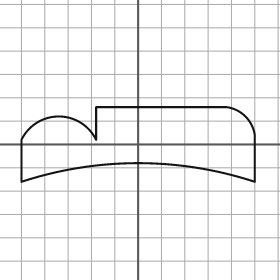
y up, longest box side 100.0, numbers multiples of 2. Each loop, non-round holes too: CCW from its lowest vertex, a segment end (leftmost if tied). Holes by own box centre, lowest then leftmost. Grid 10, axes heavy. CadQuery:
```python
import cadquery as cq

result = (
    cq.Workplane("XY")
    .moveTo(-50.0, -16.0)
    .threePointArc((0.0, -8.0), (50.0, -16.0))
    .lineTo(50.0, 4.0)
    .threePointArc((46.0, 12.0), (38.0, 16.0))
    .lineTo(-18.0, 16.0)
    .lineTo(-18.0, 2.0)
    .threePointArc((-34.0, 12.0), (-50.0, 2.0))
    .close()
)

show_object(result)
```